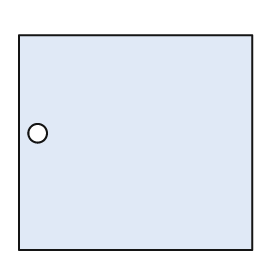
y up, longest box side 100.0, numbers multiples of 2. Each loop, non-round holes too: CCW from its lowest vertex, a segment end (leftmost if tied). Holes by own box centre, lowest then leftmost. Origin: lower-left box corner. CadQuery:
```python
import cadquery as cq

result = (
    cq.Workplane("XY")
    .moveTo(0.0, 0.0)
    .lineTo(100.0, 0.0)
    .lineTo(100.0, 92.0)
    .lineTo(0.0, 92.0)
    .close()
    .moveTo(8.0, 50.0)
    .circle(4.0)
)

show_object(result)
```